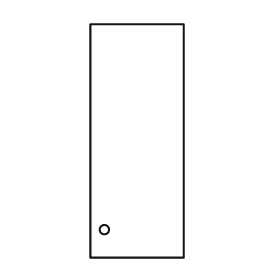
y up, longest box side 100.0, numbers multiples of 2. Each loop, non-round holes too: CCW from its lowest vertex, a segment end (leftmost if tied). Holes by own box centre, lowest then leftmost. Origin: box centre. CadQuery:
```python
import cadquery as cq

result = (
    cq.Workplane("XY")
    .moveTo(-20.0, -50.0)
    .lineTo(20.0, -50.0)
    .lineTo(20.0, 50.0)
    .lineTo(-20.0, 50.0)
    .close()
    .moveTo(-14.0, -38.0)
    .circle(2.0)
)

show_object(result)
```